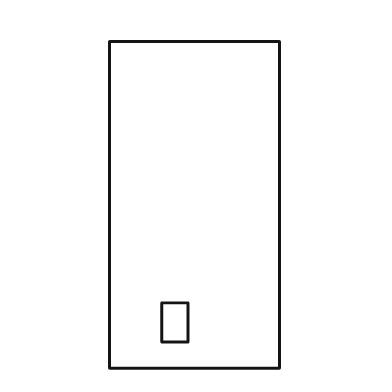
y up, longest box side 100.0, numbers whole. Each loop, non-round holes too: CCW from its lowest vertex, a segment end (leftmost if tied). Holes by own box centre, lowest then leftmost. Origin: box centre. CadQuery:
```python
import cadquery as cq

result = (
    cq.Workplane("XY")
    .moveTo(-26.0, -50.0)
    .lineTo(26.0, -50.0)
    .lineTo(26.0, 50.0)
    .lineTo(-26.0, 50.0)
    .close()
    .moveTo(-10.0, -42.0)
    .lineTo(-2.0, -42.0)
    .lineTo(-2.0, -30.0)
    .lineTo(-10.0, -30.0)
    .close()
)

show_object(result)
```